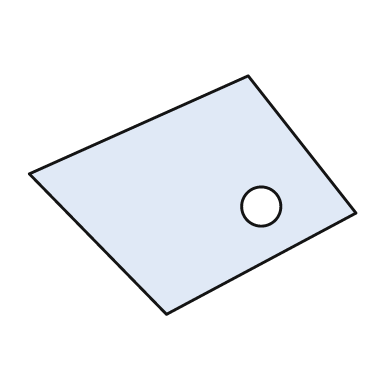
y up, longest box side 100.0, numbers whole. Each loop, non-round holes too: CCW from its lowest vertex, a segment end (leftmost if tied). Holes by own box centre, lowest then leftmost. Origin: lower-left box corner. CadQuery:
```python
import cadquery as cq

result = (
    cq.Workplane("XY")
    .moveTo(42.0, 0.0)
    .lineTo(100.0, 31.0)
    .lineTo(67.0, 73.0)
    .lineTo(0.0, 43.0)
    .close()
    .moveTo(71.0, 33.0)
    .circle(6.0)
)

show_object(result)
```